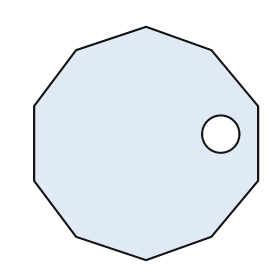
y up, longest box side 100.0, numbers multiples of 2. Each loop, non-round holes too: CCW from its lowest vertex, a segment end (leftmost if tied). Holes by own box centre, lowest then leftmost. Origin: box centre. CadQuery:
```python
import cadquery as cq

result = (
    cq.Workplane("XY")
    .moveTo(0.0, -50.0)
    .lineTo(28.0, -40.0)
    .lineTo(48.0, -16.0)
    .lineTo(48.0, 16.0)
    .lineTo(28.0, 40.0)
    .lineTo(0.0, 50.0)
    .lineTo(-30.0, 40.0)
    .lineTo(-48.0, 16.0)
    .lineTo(-48.0, -16.0)
    .lineTo(-30.0, -40.0)
    .close()
    .moveTo(32.0, 4.0)
    .circle(8.0)
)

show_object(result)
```